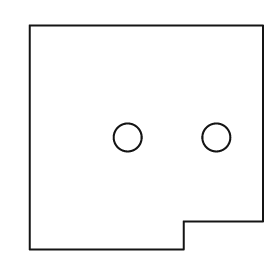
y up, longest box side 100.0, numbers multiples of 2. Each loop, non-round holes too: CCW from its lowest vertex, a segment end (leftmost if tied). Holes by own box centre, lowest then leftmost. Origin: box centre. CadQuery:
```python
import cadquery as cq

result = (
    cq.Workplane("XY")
    .moveTo(-50.0, -48.0)
    .lineTo(16.0, -48.0)
    .lineTo(16.0, -36.0)
    .lineTo(50.0, -36.0)
    .lineTo(50.0, 48.0)
    .lineTo(-50.0, 48.0)
    .close()
    .moveTo(-8.0, 0.0)
    .circle(6.0)
    .moveTo(30.0, 0.0)
    .circle(6.0)
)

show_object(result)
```